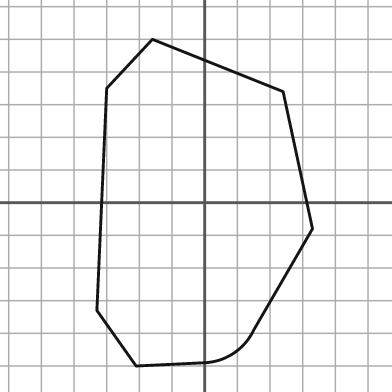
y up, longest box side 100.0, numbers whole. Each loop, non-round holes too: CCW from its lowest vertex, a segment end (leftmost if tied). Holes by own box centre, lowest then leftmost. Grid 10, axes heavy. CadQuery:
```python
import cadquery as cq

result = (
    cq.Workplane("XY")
    .moveTo(-21.0, -50.0)
    .lineTo(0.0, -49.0)
    .threePointArc((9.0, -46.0), (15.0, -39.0))
    .lineTo(33.0, -8.0)
    .lineTo(24.0, 34.0)
    .lineTo(-16.0, 50.0)
    .lineTo(-30.0, 35.0)
    .lineTo(-33.0, -33.0)
    .close()
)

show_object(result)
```